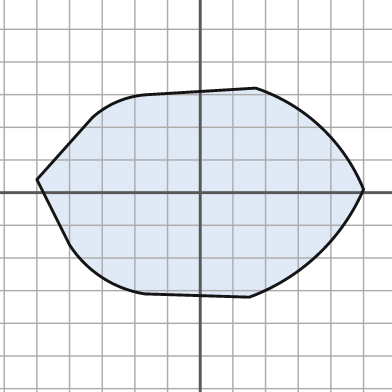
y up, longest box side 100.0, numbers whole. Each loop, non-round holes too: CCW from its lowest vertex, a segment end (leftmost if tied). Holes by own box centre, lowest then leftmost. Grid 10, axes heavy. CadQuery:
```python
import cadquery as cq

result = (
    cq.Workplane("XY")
    .moveTo(15.0, -32.0)
    .threePointArc((36.0, -19.0), (50.0, 1.0))
    .threePointArc((37.0, 20.0), (17.0, 32.0))
    .lineTo(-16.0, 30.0)
    .threePointArc((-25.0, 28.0), (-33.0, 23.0))
    .lineTo(-50.0, 4.0)
    .lineTo(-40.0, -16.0)
    .threePointArc((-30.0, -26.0), (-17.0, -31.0))
    .close()
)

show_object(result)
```